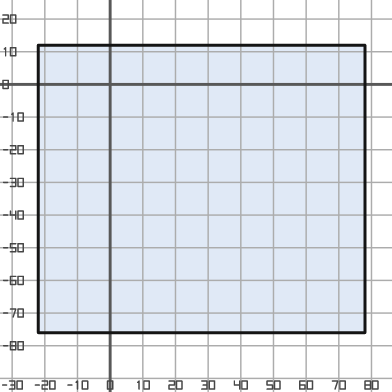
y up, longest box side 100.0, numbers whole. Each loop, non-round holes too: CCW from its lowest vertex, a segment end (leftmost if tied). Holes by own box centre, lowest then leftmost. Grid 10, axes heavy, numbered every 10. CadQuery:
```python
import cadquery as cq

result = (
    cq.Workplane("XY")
    .moveTo(-22.0, -76.0)
    .lineTo(78.0, -76.0)
    .lineTo(78.0, 12.0)
    .lineTo(-22.0, 12.0)
    .close()
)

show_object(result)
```